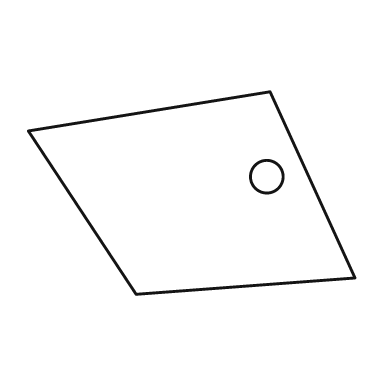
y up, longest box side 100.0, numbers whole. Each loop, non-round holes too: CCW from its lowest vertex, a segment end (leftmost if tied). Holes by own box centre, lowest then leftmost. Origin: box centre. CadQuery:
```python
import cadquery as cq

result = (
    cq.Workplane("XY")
    .moveTo(-17.0, -31.0)
    .lineTo(50.0, -26.0)
    .lineTo(24.0, 31.0)
    .lineTo(-50.0, 19.0)
    .close()
    .moveTo(23.0, 5.0)
    .circle(5.0)
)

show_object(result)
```